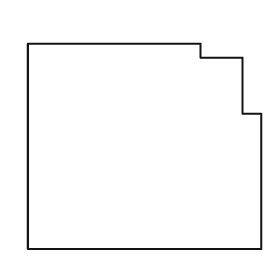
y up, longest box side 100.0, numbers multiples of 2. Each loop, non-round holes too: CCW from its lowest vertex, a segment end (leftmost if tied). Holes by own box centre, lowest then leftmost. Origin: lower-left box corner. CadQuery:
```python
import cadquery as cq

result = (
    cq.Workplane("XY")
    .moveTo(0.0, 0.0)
    .lineTo(100.0, 0.0)
    .lineTo(100.0, 58.0)
    .lineTo(92.0, 58.0)
    .lineTo(92.0, 82.0)
    .lineTo(74.0, 82.0)
    .lineTo(74.0, 88.0)
    .lineTo(0.0, 88.0)
    .close()
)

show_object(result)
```